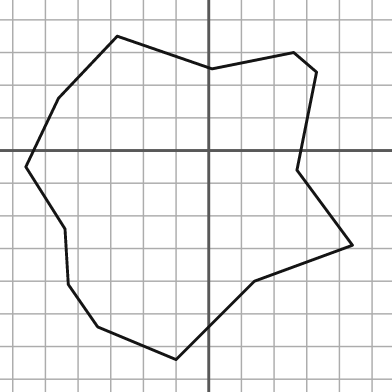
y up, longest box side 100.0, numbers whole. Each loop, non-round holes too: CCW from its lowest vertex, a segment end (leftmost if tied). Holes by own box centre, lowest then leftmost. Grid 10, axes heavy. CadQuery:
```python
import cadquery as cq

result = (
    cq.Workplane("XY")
    .moveTo(-10.0, -64.0)
    .lineTo(14.0, -40.0)
    .lineTo(44.0, -29.0)
    .lineTo(27.0, -6.0)
    .lineTo(33.0, 24.0)
    .lineTo(26.0, 30.0)
    .lineTo(1.0, 25.0)
    .lineTo(-28.0, 35.0)
    .lineTo(-46.0, 16.0)
    .lineTo(-56.0, -5.0)
    .lineTo(-44.0, -24.0)
    .lineTo(-43.0, -41.0)
    .lineTo(-34.0, -54.0)
    .close()
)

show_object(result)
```